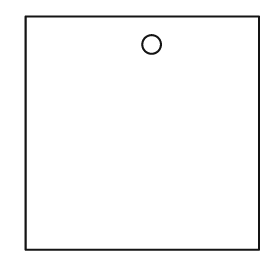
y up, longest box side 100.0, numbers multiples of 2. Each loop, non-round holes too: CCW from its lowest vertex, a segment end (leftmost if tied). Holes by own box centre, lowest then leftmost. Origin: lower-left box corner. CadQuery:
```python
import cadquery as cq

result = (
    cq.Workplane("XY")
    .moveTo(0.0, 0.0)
    .lineTo(100.0, 0.0)
    .lineTo(100.0, 100.0)
    .lineTo(0.0, 100.0)
    .close()
    .moveTo(54.0, 88.0)
    .circle(4.0)
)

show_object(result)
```